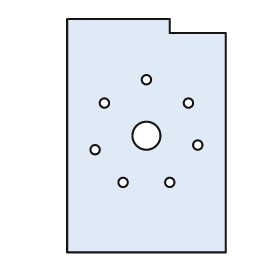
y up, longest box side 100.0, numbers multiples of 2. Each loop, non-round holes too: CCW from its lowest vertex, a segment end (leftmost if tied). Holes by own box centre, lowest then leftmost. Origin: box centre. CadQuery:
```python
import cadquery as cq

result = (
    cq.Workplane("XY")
    .moveTo(-34.0, -50.0)
    .lineTo(34.0, -50.0)
    .lineTo(34.0, 44.0)
    .lineTo(10.0, 44.0)
    .lineTo(10.0, 50.0)
    .lineTo(-34.0, 50.0)
    .close()
    .moveTo(-10.0, -20.0)
    .circle(2.0)
    .moveTo(10.0, -20.0)
    .circle(2.0)
    .moveTo(-22.0, -6.0)
    .circle(2.0)
    .moveTo(22.0, -4.0)
    .circle(2.0)
    .moveTo(0.0, 0.0)
    .circle(6.0)
    .moveTo(-18.0, 14.0)
    .circle(2.0)
    .moveTo(18.0, 14.0)
    .circle(2.0)
    .moveTo(0.0, 24.0)
    .circle(2.0)
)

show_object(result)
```